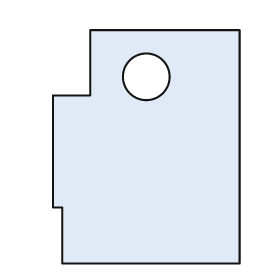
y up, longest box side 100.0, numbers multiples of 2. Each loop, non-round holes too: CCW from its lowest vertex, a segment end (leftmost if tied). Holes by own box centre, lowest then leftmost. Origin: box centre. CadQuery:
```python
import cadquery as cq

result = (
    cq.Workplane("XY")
    .moveTo(-36.0, -50.0)
    .lineTo(40.0, -50.0)
    .lineTo(40.0, 50.0)
    .lineTo(-24.0, 50.0)
    .lineTo(-24.0, 22.0)
    .lineTo(-40.0, 22.0)
    .lineTo(-40.0, -26.0)
    .lineTo(-36.0, -26.0)
    .close()
    .moveTo(0.0, 30.0)
    .circle(10.0)
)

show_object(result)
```